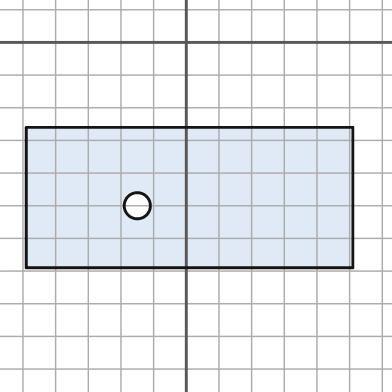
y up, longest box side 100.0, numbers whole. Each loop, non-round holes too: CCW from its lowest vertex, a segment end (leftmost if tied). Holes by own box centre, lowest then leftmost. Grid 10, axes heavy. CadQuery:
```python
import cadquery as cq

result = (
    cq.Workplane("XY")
    .moveTo(-49.0, -69.0)
    .lineTo(51.0, -69.0)
    .lineTo(51.0, -26.0)
    .lineTo(-49.0, -26.0)
    .close()
    .moveTo(-15.0, -50.0)
    .circle(4.0)
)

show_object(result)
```